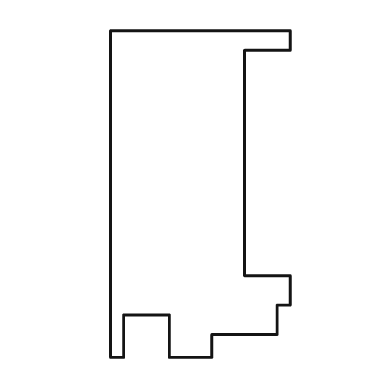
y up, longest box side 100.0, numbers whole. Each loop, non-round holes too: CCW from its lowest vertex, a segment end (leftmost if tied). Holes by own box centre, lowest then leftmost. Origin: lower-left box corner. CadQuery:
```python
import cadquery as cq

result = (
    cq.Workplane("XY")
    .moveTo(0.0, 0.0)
    .lineTo(4.0, 0.0)
    .lineTo(4.0, 13.0)
    .lineTo(18.0, 13.0)
    .lineTo(18.0, 0.0)
    .lineTo(31.0, 0.0)
    .lineTo(31.0, 7.0)
    .lineTo(51.0, 7.0)
    .lineTo(51.0, 16.0)
    .lineTo(55.0, 16.0)
    .lineTo(55.0, 25.0)
    .lineTo(41.0, 25.0)
    .lineTo(41.0, 94.0)
    .lineTo(55.0, 94.0)
    .lineTo(55.0, 100.0)
    .lineTo(0.0, 100.0)
    .close()
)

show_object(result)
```